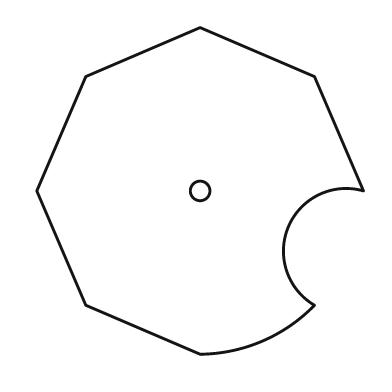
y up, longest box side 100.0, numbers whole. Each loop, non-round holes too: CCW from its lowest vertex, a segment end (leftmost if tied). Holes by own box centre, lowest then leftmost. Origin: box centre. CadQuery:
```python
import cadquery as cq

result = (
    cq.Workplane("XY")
    .moveTo(0.0, -50.0)
    .threePointArc((19.0, -46.0), (35.0, -35.0))
    .threePointArc((27.0, -11.0), (50.0, 0.0))
    .lineTo(35.0, 35.0)
    .lineTo(0.0, 50.0)
    .lineTo(-35.0, 35.0)
    .lineTo(-50.0, 0.0)
    .lineTo(-35.0, -35.0)
    .close()
    .moveTo(0.0, 0.0)
    .circle(3.0)
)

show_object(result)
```